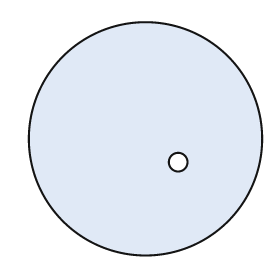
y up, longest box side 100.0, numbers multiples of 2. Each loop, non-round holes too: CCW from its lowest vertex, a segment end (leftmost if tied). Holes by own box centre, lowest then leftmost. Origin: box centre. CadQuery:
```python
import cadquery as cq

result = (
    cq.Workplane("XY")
    .moveTo(0.0, 0.0)
    .circle(50.0)
    .moveTo(14.0, -10.0)
    .circle(4.0)
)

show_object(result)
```